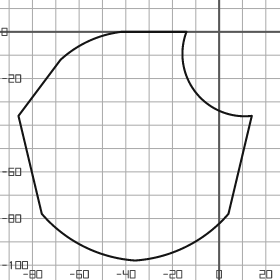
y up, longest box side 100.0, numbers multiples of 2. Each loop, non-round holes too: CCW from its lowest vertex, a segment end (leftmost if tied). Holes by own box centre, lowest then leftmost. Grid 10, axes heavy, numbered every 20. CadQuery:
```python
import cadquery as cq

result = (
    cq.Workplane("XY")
    .moveTo(-36.0, -98.0)
    .threePointArc((-14.0, -92.0), (4.0, -78.0))
    .lineTo(14.0, -36.0)
    .threePointArc((-10.0, -26.0), (-14.0, 0.0))
    .lineTo(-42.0, 0.0)
    .threePointArc((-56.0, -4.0), (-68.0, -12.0))
    .lineTo(-86.0, -36.0)
    .lineTo(-76.0, -78.0)
    .threePointArc((-58.0, -92.0), (-36.0, -98.0))
    .close()
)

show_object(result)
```